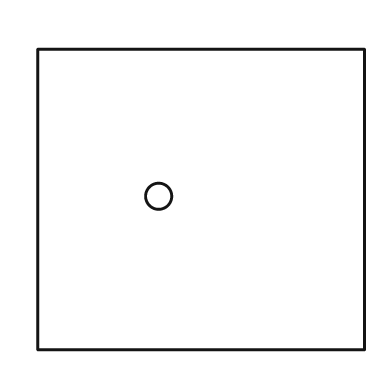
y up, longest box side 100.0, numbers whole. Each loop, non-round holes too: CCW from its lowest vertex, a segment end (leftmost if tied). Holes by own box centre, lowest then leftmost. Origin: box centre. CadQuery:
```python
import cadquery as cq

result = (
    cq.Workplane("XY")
    .moveTo(-50.0, -46.0)
    .lineTo(50.0, -46.0)
    .lineTo(50.0, 46.0)
    .lineTo(-50.0, 46.0)
    .close()
    .moveTo(-13.0, 1.0)
    .circle(4.0)
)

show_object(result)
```